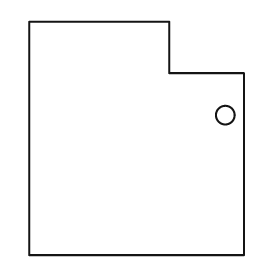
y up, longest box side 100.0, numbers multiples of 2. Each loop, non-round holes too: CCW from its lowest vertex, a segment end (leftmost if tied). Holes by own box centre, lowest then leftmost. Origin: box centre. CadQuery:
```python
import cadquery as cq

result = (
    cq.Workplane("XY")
    .moveTo(-46.0, -50.0)
    .lineTo(46.0, -50.0)
    .lineTo(46.0, 28.0)
    .lineTo(14.0, 28.0)
    .lineTo(14.0, 50.0)
    .lineTo(-46.0, 50.0)
    .close()
    .moveTo(38.0, 10.0)
    .circle(4.0)
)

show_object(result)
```